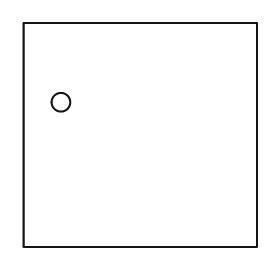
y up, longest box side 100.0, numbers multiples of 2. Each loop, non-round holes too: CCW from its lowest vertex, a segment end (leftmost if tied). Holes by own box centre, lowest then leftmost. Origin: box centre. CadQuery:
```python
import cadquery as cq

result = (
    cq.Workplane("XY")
    .moveTo(-50.0, -48.0)
    .lineTo(50.0, -48.0)
    .lineTo(50.0, 48.0)
    .lineTo(-50.0, 48.0)
    .close()
    .moveTo(-34.0, 14.0)
    .circle(4.0)
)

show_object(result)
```